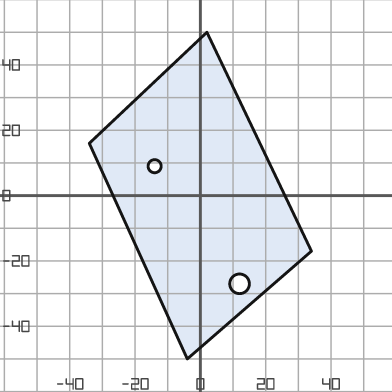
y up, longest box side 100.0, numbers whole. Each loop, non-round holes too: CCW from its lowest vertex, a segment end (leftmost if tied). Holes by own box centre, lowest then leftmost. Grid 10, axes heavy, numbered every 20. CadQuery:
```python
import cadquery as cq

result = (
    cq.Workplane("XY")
    .moveTo(-4.0, -50.0)
    .lineTo(34.0, -17.0)
    .lineTo(2.0, 50.0)
    .lineTo(-34.0, 16.0)
    .close()
    .moveTo(12.0, -27.0)
    .circle(3.0)
    .moveTo(-14.0, 9.0)
    .circle(2.0)
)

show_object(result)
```